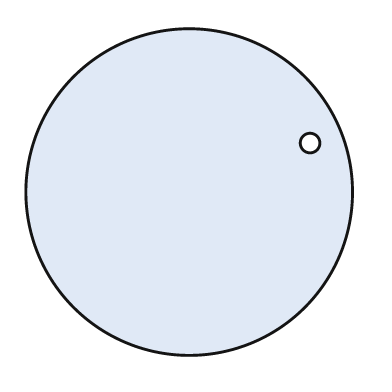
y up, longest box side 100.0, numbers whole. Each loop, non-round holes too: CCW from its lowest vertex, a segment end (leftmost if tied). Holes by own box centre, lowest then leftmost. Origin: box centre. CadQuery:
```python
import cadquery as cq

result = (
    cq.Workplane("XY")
    .moveTo(0.0, 0.0)
    .circle(50.0)
    .moveTo(37.0, 15.0)
    .circle(3.0)
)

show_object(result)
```